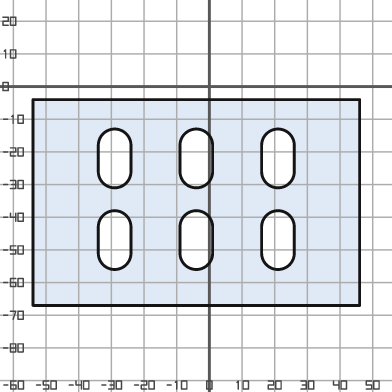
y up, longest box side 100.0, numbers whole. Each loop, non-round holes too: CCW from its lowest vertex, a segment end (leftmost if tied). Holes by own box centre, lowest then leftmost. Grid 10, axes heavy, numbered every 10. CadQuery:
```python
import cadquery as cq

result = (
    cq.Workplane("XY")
    .moveTo(-54.0, -67.0)
    .lineTo(46.0, -67.0)
    .lineTo(46.0, -4.0)
    .lineTo(-54.0, -4.0)
    .close()
    .moveTo(-34.0, -51.0)
    .threePointArc((-29.0, -56.0), (-24.0, -51.0))
    .lineTo(-24.0, -43.0)
    .threePointArc((-29.0, -38.0), (-34.0, -43.0))
    .close()
    .moveTo(-9.0, -51.0)
    .threePointArc((-4.0, -56.0), (1.0, -51.0))
    .lineTo(1.0, -43.0)
    .threePointArc((-4.0, -38.0), (-9.0, -43.0))
    .close()
    .moveTo(16.0, -51.0)
    .threePointArc((21.0, -56.0), (26.0, -51.0))
    .lineTo(26.0, -43.0)
    .threePointArc((21.0, -38.0), (16.0, -43.0))
    .close()
    .moveTo(-34.0, -26.0)
    .threePointArc((-29.0, -31.0), (-24.0, -26.0))
    .lineTo(-24.0, -18.0)
    .threePointArc((-29.0, -13.0), (-34.0, -18.0))
    .close()
    .moveTo(-9.0, -26.0)
    .threePointArc((-4.0, -31.0), (1.0, -26.0))
    .lineTo(1.0, -18.0)
    .threePointArc((-4.0, -13.0), (-9.0, -18.0))
    .close()
    .moveTo(16.0, -26.0)
    .threePointArc((21.0, -31.0), (26.0, -26.0))
    .lineTo(26.0, -18.0)
    .threePointArc((21.0, -13.0), (16.0, -18.0))
    .close()
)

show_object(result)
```